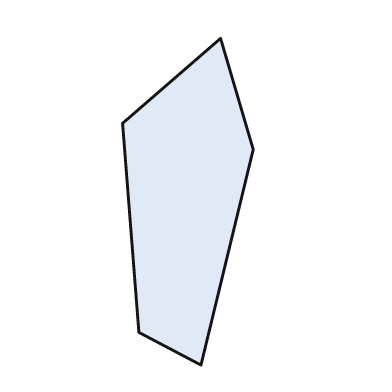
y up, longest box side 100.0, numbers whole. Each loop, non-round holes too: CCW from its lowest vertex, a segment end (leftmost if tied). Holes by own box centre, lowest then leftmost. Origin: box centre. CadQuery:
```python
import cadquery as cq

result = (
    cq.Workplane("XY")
    .moveTo(4.0, -50.0)
    .lineTo(20.0, 16.0)
    .lineTo(10.0, 50.0)
    .lineTo(-20.0, 24.0)
    .lineTo(-15.0, -40.0)
    .close()
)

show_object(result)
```